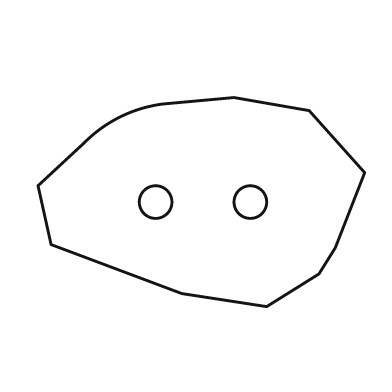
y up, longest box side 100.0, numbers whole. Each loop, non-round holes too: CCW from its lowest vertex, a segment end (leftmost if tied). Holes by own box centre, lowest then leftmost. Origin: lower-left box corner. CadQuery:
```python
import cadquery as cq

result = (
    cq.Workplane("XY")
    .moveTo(70.0, 0.0)
    .lineTo(86.0, 10.0)
    .lineTo(91.0, 18.0)
    .lineTo(100.0, 41.0)
    .lineTo(83.0, 60.0)
    .lineTo(60.0, 64.0)
    .lineTo(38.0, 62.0)
    .threePointArc((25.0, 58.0), (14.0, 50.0))
    .lineTo(0.0, 37.0)
    .lineTo(4.0, 19.0)
    .lineTo(44.0, 4.0)
    .close()
    .moveTo(36.0, 32.0)
    .circle(5.0)
    .moveTo(65.0, 32.0)
    .circle(5.0)
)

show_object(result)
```